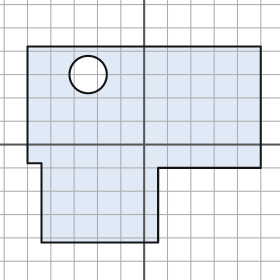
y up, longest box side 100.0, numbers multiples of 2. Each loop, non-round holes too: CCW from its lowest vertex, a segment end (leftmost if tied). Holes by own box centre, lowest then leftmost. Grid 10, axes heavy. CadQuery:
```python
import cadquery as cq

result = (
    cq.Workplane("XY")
    .moveTo(-44.0, -42.0)
    .lineTo(6.0, -42.0)
    .lineTo(6.0, -10.0)
    .lineTo(50.0, -10.0)
    .lineTo(50.0, 42.0)
    .lineTo(-50.0, 42.0)
    .lineTo(-50.0, -8.0)
    .lineTo(-44.0, -8.0)
    .close()
    .moveTo(-24.0, 30.0)
    .circle(8.0)
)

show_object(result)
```